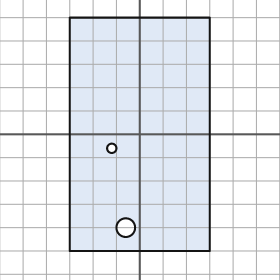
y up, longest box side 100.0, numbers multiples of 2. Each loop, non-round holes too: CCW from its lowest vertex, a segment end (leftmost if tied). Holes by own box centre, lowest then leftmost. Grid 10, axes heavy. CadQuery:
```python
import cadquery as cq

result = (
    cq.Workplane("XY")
    .moveTo(-30.0, -50.0)
    .lineTo(30.0, -50.0)
    .lineTo(30.0, 50.0)
    .lineTo(-30.0, 50.0)
    .close()
    .moveTo(-6.0, -40.0)
    .circle(4.0)
    .moveTo(-12.0, -6.0)
    .circle(2.0)
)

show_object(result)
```